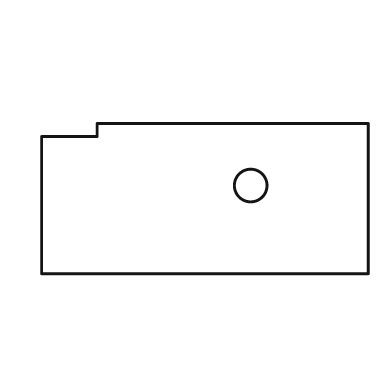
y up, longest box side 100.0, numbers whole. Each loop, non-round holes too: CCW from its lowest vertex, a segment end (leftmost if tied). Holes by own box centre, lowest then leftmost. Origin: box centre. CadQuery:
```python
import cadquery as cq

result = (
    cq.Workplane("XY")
    .moveTo(-50.0, -23.0)
    .lineTo(50.0, -23.0)
    .lineTo(50.0, 23.0)
    .lineTo(-33.0, 23.0)
    .lineTo(-33.0, 19.0)
    .lineTo(-50.0, 19.0)
    .close()
    .moveTo(14.0, 4.0)
    .circle(5.0)
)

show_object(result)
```